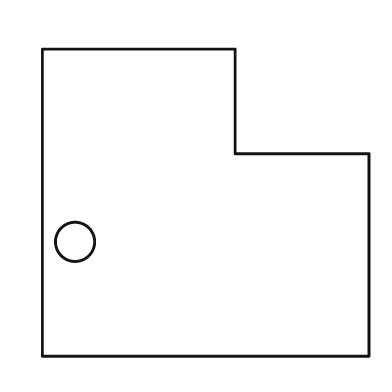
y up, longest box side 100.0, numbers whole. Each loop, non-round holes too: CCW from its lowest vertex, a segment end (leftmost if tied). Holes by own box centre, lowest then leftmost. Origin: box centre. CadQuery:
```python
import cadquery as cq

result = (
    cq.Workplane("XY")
    .moveTo(-50.0, -47.0)
    .lineTo(50.0, -47.0)
    .lineTo(50.0, 15.0)
    .lineTo(9.0, 15.0)
    .lineTo(9.0, 47.0)
    .lineTo(-50.0, 47.0)
    .close()
    .moveTo(-40.0, -12.0)
    .circle(6.0)
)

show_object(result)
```